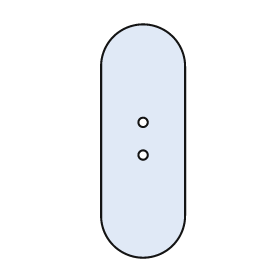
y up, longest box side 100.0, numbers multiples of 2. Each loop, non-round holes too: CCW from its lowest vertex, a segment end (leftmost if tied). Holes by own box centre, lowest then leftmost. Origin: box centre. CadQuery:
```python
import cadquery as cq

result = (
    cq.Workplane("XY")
    .moveTo(-18.0, -32.0)
    .threePointArc((0.0, -50.0), (18.0, -32.0))
    .lineTo(18.0, 32.0)
    .threePointArc((0.0, 50.0), (-18.0, 32.0))
    .close()
    .moveTo(0.0, -6.0)
    .circle(2.0)
    .moveTo(0.0, 8.0)
    .circle(2.0)
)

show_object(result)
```